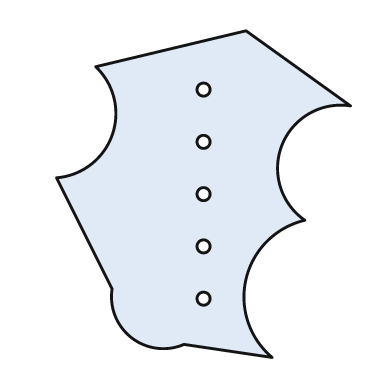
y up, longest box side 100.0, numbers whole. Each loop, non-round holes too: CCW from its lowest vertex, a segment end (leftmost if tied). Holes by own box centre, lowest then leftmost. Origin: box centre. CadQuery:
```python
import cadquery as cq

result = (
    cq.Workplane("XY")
    .moveTo(21.0, -50.0)
    .threePointArc((13.0, -26.0), (31.0, -8.0))
    .threePointArc((24.0, 15.0), (45.0, 27.0))
    .lineTo(13.0, 50.0)
    .lineTo(-33.0, 39.0)
    .threePointArc((-28.0, 18.0), (-45.0, 5.0))
    .lineTo(-28.0, -29.0)
    .threePointArc((-22.0, -44.0), (-6.0, -46.0))
    .close()
    .moveTo(0.0, -32.0)
    .circle(2.0)
    .moveTo(0.0, -16.0)
    .circle(2.0)
    .moveTo(0.0, 0.0)
    .circle(2.0)
    .moveTo(0.0, 16.0)
    .circle(2.0)
    .moveTo(0.0, 32.0)
    .circle(2.0)
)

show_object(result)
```